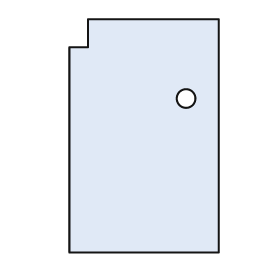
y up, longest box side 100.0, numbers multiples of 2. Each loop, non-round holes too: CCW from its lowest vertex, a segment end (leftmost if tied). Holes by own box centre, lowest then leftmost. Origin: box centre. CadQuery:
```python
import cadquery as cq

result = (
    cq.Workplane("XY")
    .moveTo(-32.0, -50.0)
    .lineTo(32.0, -50.0)
    .lineTo(32.0, 50.0)
    .lineTo(-24.0, 50.0)
    .lineTo(-24.0, 38.0)
    .lineTo(-32.0, 38.0)
    .close()
    .moveTo(18.0, 16.0)
    .circle(4.0)
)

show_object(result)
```